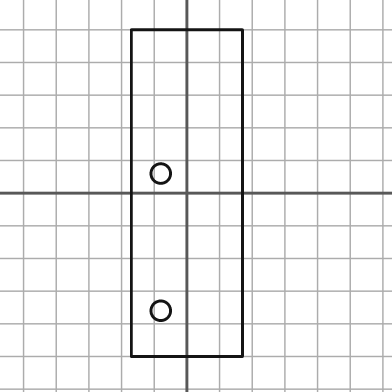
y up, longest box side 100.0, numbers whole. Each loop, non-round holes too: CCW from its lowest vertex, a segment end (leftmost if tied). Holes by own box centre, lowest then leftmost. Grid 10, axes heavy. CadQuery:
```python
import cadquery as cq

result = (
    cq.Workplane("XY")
    .moveTo(-17.0, -50.0)
    .lineTo(17.0, -50.0)
    .lineTo(17.0, 50.0)
    .lineTo(-17.0, 50.0)
    .close()
    .moveTo(-8.0, -36.0)
    .circle(3.0)
    .moveTo(-8.0, 6.0)
    .circle(3.0)
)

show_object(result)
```